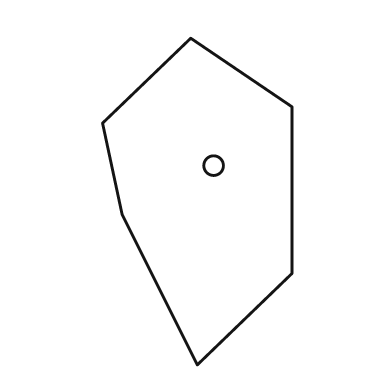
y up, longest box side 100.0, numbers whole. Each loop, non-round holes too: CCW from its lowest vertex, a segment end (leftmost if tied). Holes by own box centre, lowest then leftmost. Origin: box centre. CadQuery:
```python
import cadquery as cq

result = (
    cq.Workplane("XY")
    .moveTo(0.0, -50.0)
    .lineTo(29.0, -22.0)
    .lineTo(29.0, 29.0)
    .lineTo(-2.0, 50.0)
    .lineTo(-29.0, 24.0)
    .lineTo(-23.0, -4.0)
    .close()
    .moveTo(5.0, 11.0)
    .circle(3.0)
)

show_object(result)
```